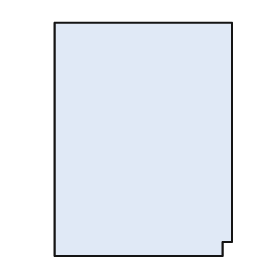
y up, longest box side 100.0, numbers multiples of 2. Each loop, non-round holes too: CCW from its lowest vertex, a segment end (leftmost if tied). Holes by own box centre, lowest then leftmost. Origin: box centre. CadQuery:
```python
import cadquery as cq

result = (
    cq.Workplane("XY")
    .moveTo(-38.0, -50.0)
    .lineTo(34.0, -50.0)
    .lineTo(34.0, -44.0)
    .lineTo(38.0, -44.0)
    .lineTo(38.0, 50.0)
    .lineTo(-38.0, 50.0)
    .close()
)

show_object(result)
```